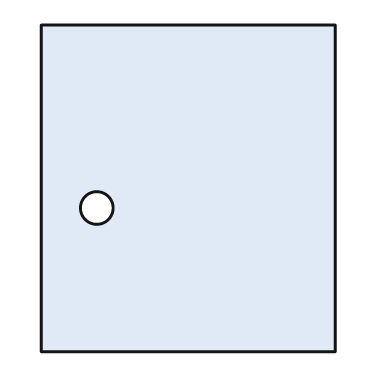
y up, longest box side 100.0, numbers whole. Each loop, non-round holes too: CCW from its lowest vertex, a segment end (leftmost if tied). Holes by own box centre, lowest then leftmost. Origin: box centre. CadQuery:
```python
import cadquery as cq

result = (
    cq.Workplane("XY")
    .moveTo(-45.0, -50.0)
    .lineTo(45.0, -50.0)
    .lineTo(45.0, 50.0)
    .lineTo(-45.0, 50.0)
    .close()
    .moveTo(-28.0, -6.0)
    .circle(5.0)
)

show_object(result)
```